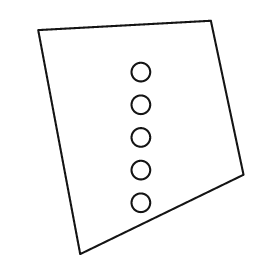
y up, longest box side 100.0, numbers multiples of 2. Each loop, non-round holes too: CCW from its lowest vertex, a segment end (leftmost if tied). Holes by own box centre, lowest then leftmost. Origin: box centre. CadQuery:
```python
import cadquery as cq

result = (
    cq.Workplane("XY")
    .moveTo(-26.0, -50.0)
    .lineTo(44.0, -16.0)
    .lineTo(30.0, 50.0)
    .lineTo(-44.0, 46.0)
    .close()
    .moveTo(0.0, -28.0)
    .circle(4.0)
    .moveTo(0.0, -14.0)
    .circle(4.0)
    .moveTo(0.0, 0.0)
    .circle(4.0)
    .moveTo(0.0, 14.0)
    .circle(4.0)
    .moveTo(0.0, 28.0)
    .circle(4.0)
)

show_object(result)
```